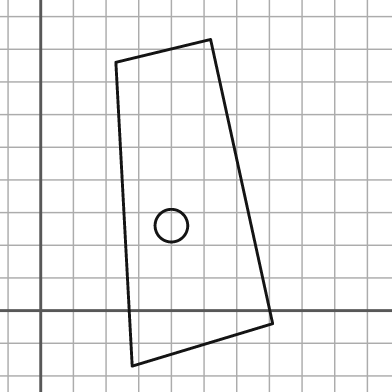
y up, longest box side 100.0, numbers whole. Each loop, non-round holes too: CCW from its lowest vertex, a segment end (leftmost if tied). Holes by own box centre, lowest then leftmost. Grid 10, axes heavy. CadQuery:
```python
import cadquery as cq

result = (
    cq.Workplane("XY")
    .moveTo(28.0, -17.0)
    .lineTo(71.0, -4.0)
    .lineTo(52.0, 83.0)
    .lineTo(23.0, 76.0)
    .close()
    .moveTo(40.0, 26.0)
    .circle(5.0)
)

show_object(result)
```